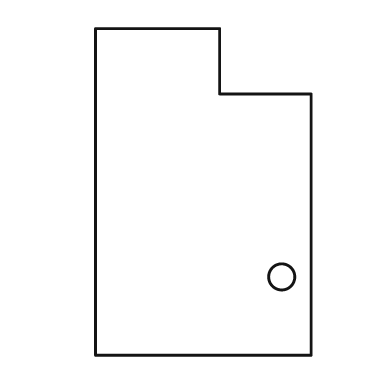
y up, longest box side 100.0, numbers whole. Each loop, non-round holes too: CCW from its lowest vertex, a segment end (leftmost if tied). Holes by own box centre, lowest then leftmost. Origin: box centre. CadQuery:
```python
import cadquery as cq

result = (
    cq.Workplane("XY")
    .moveTo(-33.0, -50.0)
    .lineTo(33.0, -50.0)
    .lineTo(33.0, 30.0)
    .lineTo(5.0, 30.0)
    .lineTo(5.0, 50.0)
    .lineTo(-33.0, 50.0)
    .close()
    .moveTo(24.0, -26.0)
    .circle(4.0)
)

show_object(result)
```